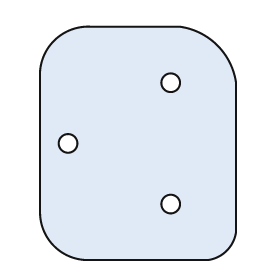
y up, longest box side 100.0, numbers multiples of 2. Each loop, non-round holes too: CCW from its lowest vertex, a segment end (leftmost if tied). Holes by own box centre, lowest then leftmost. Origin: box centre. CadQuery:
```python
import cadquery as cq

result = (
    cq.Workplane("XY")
    .moveTo(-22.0, -50.0)
    .lineTo(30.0, -50.0)
    .threePointArc((38.0, -46.0), (42.0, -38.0))
    .lineTo(42.0, 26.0)
    .threePointArc((34.0, 42.0), (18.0, 50.0))
    .lineTo(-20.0, 50.0)
    .threePointArc((-36.0, 44.0), (-42.0, 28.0))
    .lineTo(-42.0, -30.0)
    .threePointArc((-36.0, -44.0), (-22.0, -50.0))
    .close()
    .moveTo(14.0, -26.0)
    .circle(4.0)
    .moveTo(-30.0, 0.0)
    .circle(4.0)
    .moveTo(14.0, 26.0)
    .circle(4.0)
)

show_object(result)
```